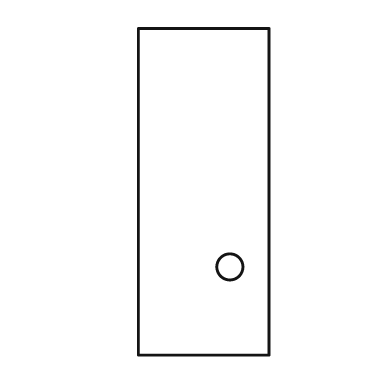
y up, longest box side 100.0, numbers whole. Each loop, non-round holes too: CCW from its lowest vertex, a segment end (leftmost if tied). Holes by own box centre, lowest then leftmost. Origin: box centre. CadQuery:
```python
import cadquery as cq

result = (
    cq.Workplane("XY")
    .moveTo(-20.0, -50.0)
    .lineTo(20.0, -50.0)
    .lineTo(20.0, 50.0)
    .lineTo(-20.0, 50.0)
    .close()
    .moveTo(8.0, -23.0)
    .circle(4.0)
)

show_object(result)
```